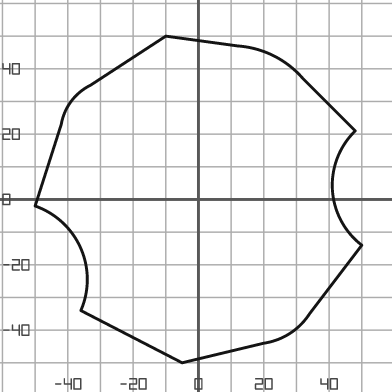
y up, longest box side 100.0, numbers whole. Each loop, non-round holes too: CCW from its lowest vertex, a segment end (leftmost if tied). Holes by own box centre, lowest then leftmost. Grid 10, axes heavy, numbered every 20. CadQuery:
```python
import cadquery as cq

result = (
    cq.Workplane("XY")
    .moveTo(-5.0, -50.0)
    .lineTo(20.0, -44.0)
    .threePointArc((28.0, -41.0), (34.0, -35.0))
    .lineTo(50.0, -14.0)
    .threePointArc((41.0, 3.0), (48.0, 21.0))
    .lineTo(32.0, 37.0)
    .threePointArc((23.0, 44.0), (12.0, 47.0))
    .lineTo(-10.0, 50.0)
    .lineTo(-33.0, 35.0)
    .threePointArc((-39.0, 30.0), (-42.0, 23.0))
    .lineTo(-50.0, -2.0)
    .threePointArc((-36.0, -15.0), (-36.0, -34.0))
    .close()
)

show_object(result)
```